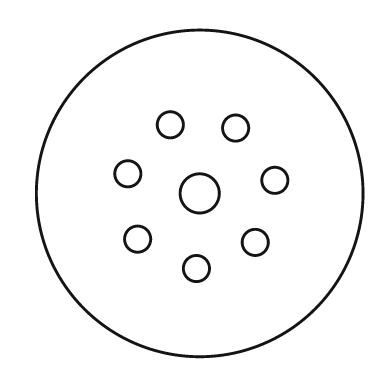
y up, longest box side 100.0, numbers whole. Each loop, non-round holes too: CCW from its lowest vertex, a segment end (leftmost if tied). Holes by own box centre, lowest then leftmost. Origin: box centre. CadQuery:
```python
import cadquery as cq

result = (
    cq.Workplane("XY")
    .moveTo(0.0, 0.0)
    .circle(50.0)
    .moveTo(-1.0, -23.0)
    .circle(4.0)
    .moveTo(17.0, -15.0)
    .circle(4.0)
    .moveTo(-19.0, -14.0)
    .circle(4.0)
    .moveTo(0.0, 0.0)
    .circle(6.0)
    .moveTo(23.0, 4.0)
    .circle(4.0)
    .moveTo(-22.0, 6.0)
    .circle(4.0)
    .moveTo(11.0, 20.0)
    .circle(4.0)
    .moveTo(-9.0, 21.0)
    .circle(4.0)
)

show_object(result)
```